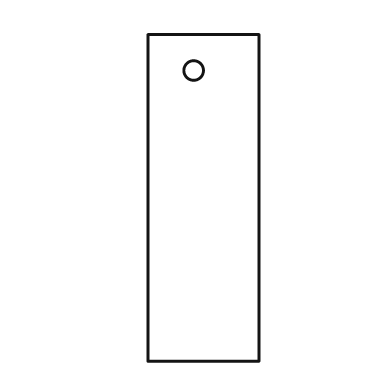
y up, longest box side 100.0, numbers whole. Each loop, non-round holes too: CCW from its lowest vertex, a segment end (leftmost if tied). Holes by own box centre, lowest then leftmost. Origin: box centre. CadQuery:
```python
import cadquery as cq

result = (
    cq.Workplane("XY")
    .moveTo(-17.0, -50.0)
    .lineTo(17.0, -50.0)
    .lineTo(17.0, 50.0)
    .lineTo(-17.0, 50.0)
    .close()
    .moveTo(-3.0, 39.0)
    .circle(3.0)
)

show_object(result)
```